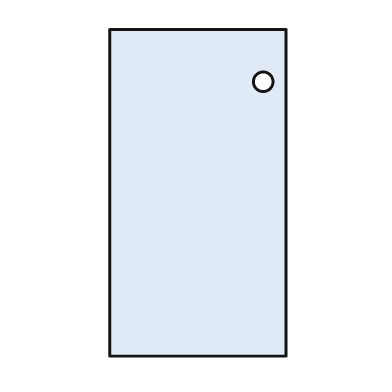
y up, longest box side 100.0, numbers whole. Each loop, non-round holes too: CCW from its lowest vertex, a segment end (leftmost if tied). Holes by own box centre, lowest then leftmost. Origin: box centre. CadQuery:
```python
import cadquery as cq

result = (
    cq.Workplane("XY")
    .moveTo(-27.0, -50.0)
    .lineTo(27.0, -50.0)
    .lineTo(27.0, 50.0)
    .lineTo(-27.0, 50.0)
    .close()
    .moveTo(20.0, 34.0)
    .circle(3.0)
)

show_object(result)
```